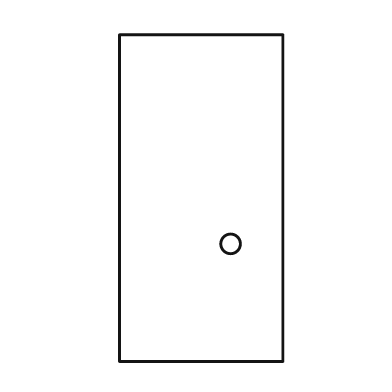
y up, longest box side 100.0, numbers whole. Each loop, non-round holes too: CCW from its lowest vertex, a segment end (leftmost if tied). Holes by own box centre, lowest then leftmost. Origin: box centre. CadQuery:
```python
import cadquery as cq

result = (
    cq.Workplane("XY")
    .moveTo(-25.0, -50.0)
    .lineTo(25.0, -50.0)
    .lineTo(25.0, 50.0)
    .lineTo(-25.0, 50.0)
    .close()
    .moveTo(9.0, -14.0)
    .circle(3.0)
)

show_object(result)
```